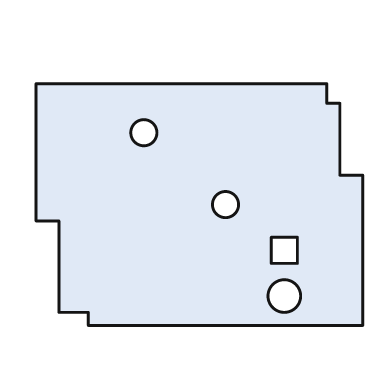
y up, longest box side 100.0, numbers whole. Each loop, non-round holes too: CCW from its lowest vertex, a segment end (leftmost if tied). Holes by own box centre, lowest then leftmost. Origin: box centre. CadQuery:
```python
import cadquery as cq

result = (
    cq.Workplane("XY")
    .moveTo(-34.0, -37.0)
    .lineTo(50.0, -37.0)
    .lineTo(50.0, 9.0)
    .lineTo(43.0, 9.0)
    .lineTo(43.0, 31.0)
    .lineTo(39.0, 31.0)
    .lineTo(39.0, 37.0)
    .lineTo(-50.0, 37.0)
    .lineTo(-50.0, -5.0)
    .lineTo(-43.0, -5.0)
    .lineTo(-43.0, -33.0)
    .lineTo(-34.0, -33.0)
    .close()
    .moveTo(26.0, -28.0)
    .circle(5.0)
    .moveTo(22.0, -18.0)
    .lineTo(30.0, -18.0)
    .lineTo(30.0, -10.0)
    .lineTo(22.0, -10.0)
    .close()
    .moveTo(8.0, 0.0)
    .circle(4.0)
    .moveTo(-17.0, 22.0)
    .circle(4.0)
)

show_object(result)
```